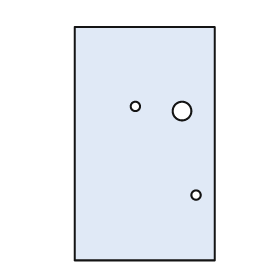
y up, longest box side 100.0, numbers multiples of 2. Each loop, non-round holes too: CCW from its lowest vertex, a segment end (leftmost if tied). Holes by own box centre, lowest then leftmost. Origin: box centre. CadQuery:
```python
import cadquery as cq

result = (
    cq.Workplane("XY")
    .moveTo(-30.0, -50.0)
    .lineTo(30.0, -50.0)
    .lineTo(30.0, 50.0)
    .lineTo(-30.0, 50.0)
    .close()
    .moveTo(22.0, -22.0)
    .circle(2.0)
    .moveTo(16.0, 14.0)
    .circle(4.0)
    .moveTo(-4.0, 16.0)
    .circle(2.0)
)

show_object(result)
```